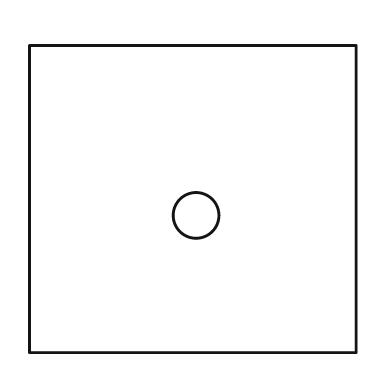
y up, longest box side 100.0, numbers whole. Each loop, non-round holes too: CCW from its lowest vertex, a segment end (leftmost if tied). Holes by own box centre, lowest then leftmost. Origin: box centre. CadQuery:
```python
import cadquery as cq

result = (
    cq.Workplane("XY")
    .moveTo(-50.0, -47.0)
    .lineTo(50.0, -47.0)
    .lineTo(50.0, 47.0)
    .lineTo(-50.0, 47.0)
    .close()
    .moveTo(1.0, -5.0)
    .circle(7.0)
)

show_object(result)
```